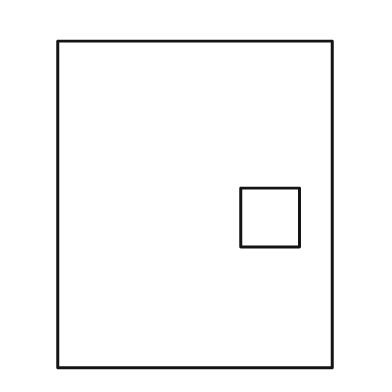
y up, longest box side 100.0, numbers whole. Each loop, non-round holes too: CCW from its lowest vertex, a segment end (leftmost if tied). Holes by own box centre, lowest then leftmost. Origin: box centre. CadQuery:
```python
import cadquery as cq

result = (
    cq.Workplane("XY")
    .moveTo(-42.0, -50.0)
    .lineTo(42.0, -50.0)
    .lineTo(42.0, 50.0)
    .lineTo(-42.0, 50.0)
    .close()
    .moveTo(14.0, -13.0)
    .lineTo(32.0, -13.0)
    .lineTo(32.0, 5.0)
    .lineTo(14.0, 5.0)
    .close()
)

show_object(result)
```